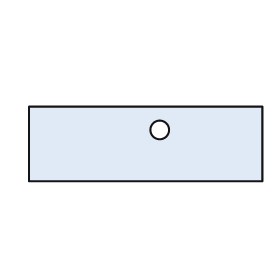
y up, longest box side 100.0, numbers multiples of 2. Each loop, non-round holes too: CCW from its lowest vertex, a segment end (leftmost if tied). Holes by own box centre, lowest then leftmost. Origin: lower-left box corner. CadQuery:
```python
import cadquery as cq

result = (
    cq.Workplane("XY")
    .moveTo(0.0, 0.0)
    .lineTo(100.0, 0.0)
    .lineTo(100.0, 32.0)
    .lineTo(0.0, 32.0)
    .close()
    .moveTo(56.0, 22.0)
    .circle(4.0)
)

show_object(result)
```